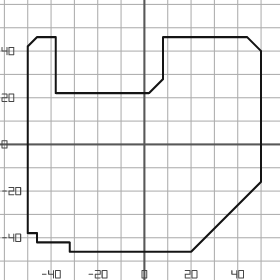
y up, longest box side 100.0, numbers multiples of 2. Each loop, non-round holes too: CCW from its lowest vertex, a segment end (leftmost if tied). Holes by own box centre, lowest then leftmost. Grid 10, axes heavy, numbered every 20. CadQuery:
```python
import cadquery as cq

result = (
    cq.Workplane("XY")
    .moveTo(-32.0, -46.0)
    .lineTo(20.0, -46.0)
    .lineTo(50.0, -16.0)
    .lineTo(50.0, 40.0)
    .lineTo(44.0, 46.0)
    .lineTo(8.0, 46.0)
    .lineTo(8.0, 28.0)
    .lineTo(2.0, 22.0)
    .lineTo(-38.0, 22.0)
    .lineTo(-38.0, 46.0)
    .lineTo(-46.0, 46.0)
    .lineTo(-50.0, 42.0)
    .lineTo(-50.0, -38.0)
    .lineTo(-46.0, -38.0)
    .lineTo(-46.0, -42.0)
    .lineTo(-32.0, -42.0)
    .close()
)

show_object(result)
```